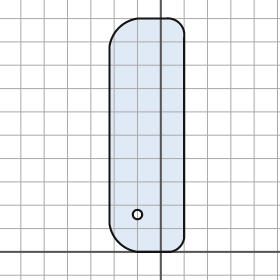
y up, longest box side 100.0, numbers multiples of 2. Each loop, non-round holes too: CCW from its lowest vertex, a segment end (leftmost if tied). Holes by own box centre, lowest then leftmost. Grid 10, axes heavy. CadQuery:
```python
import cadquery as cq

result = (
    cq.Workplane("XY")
    .moveTo(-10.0, 0.0)
    .lineTo(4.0, 0.0)
    .threePointArc((8.0, 2.0), (10.0, 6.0))
    .lineTo(10.0, 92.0)
    .threePointArc((8.0, 98.0), (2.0, 100.0))
    .lineTo(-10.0, 100.0)
    .threePointArc((-18.0, 96.0), (-22.0, 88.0))
    .lineTo(-22.0, 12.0)
    .threePointArc((-18.0, 4.0), (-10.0, 0.0))
    .close()
    .moveTo(-10.0, 16.0)
    .circle(2.0)
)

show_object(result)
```